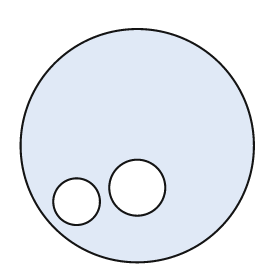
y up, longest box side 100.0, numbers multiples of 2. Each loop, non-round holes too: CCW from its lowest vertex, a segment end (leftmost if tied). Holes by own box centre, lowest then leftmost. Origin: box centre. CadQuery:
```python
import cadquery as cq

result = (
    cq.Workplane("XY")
    .moveTo(0.0, 0.0)
    .circle(50.0)
    .moveTo(-26.0, -24.0)
    .circle(10.0)
    .moveTo(0.0, -18.0)
    .circle(12.0)
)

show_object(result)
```